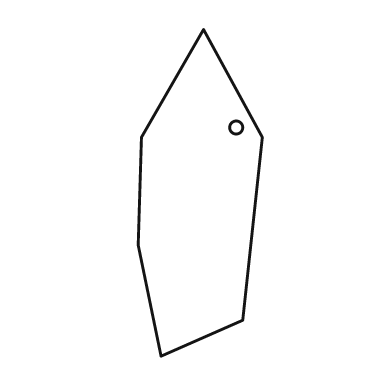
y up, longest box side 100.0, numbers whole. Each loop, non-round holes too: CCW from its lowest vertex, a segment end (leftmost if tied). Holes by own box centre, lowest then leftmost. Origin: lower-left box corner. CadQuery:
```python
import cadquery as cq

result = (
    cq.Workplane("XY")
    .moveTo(7.0, 0.0)
    .lineTo(32.0, 11.0)
    .lineTo(38.0, 67.0)
    .lineTo(20.0, 100.0)
    .lineTo(1.0, 67.0)
    .lineTo(0.0, 34.0)
    .close()
    .moveTo(30.0, 70.0)
    .circle(2.0)
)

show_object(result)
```